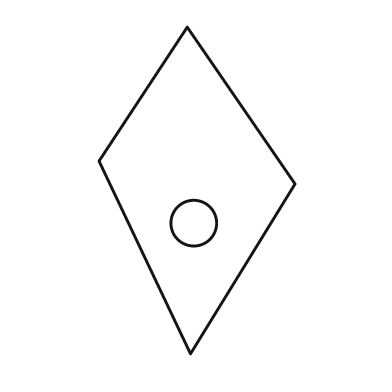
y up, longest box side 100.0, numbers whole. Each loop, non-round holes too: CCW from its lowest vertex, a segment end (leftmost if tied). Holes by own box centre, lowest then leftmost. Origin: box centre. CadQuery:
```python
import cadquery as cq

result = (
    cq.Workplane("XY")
    .moveTo(-2.0, -50.0)
    .lineTo(30.0, 2.0)
    .lineTo(-3.0, 50.0)
    .lineTo(-30.0, 9.0)
    .close()
    .moveTo(-1.0, -10.0)
    .circle(7.0)
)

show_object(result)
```